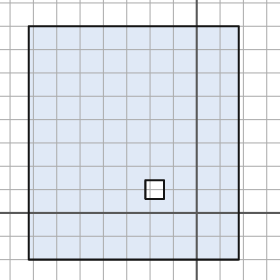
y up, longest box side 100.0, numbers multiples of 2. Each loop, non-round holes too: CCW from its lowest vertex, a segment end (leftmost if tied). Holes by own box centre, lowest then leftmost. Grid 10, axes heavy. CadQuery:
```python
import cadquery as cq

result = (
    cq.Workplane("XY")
    .moveTo(-72.0, -20.0)
    .lineTo(18.0, -20.0)
    .lineTo(18.0, 80.0)
    .lineTo(-72.0, 80.0)
    .close()
    .moveTo(-22.0, 6.0)
    .lineTo(-14.0, 6.0)
    .lineTo(-14.0, 14.0)
    .lineTo(-22.0, 14.0)
    .close()
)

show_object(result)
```